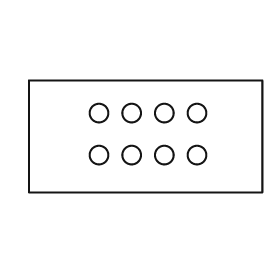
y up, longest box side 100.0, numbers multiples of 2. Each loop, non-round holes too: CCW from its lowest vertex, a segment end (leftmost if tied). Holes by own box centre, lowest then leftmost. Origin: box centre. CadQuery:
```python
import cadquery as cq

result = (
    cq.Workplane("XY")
    .moveTo(-50.0, -24.0)
    .lineTo(50.0, -24.0)
    .lineTo(50.0, 24.0)
    .lineTo(-50.0, 24.0)
    .close()
    .moveTo(-20.0, -8.0)
    .circle(4.0)
    .moveTo(-6.0, -8.0)
    .circle(4.0)
    .moveTo(8.0, -8.0)
    .circle(4.0)
    .moveTo(22.0, -8.0)
    .circle(4.0)
    .moveTo(-20.0, 10.0)
    .circle(4.0)
    .moveTo(-6.0, 10.0)
    .circle(4.0)
    .moveTo(8.0, 10.0)
    .circle(4.0)
    .moveTo(22.0, 10.0)
    .circle(4.0)
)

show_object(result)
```